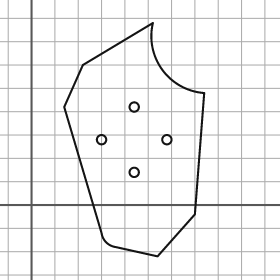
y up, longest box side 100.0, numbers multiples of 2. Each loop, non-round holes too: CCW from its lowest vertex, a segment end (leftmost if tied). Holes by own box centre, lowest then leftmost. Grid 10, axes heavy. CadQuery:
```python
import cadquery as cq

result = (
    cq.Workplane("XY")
    .moveTo(54.0, -22.0)
    .lineTo(70.0, -4.0)
    .lineTo(74.0, 48.0)
    .threePointArc((56.0, 58.0), (52.0, 78.0))
    .lineTo(22.0, 60.0)
    .lineTo(14.0, 42.0)
    .lineTo(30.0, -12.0)
    .threePointArc((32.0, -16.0), (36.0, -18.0))
    .close()
    .moveTo(44.0, 14.0)
    .circle(2.0)
    .moveTo(30.0, 28.0)
    .circle(2.0)
    .moveTo(58.0, 28.0)
    .circle(2.0)
    .moveTo(44.0, 42.0)
    .circle(2.0)
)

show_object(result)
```